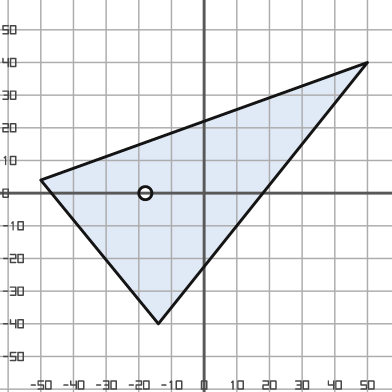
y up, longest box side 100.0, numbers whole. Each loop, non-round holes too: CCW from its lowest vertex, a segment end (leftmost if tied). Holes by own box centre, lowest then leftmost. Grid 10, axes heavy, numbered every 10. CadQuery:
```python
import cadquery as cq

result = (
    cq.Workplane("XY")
    .moveTo(-14.0, -40.0)
    .lineTo(50.0, 40.0)
    .lineTo(-50.0, 4.0)
    .close()
    .moveTo(-18.0, 0.0)
    .circle(2.0)
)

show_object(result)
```